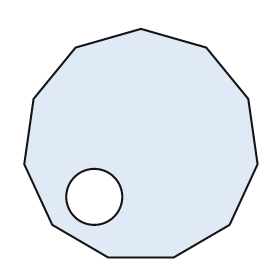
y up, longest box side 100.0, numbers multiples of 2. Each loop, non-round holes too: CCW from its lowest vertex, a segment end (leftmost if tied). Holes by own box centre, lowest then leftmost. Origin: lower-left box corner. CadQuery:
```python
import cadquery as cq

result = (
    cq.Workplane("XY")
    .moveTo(36.0, 0.0)
    .lineTo(64.0, 0.0)
    .lineTo(88.0, 14.0)
    .lineTo(100.0, 40.0)
    .lineTo(96.0, 68.0)
    .lineTo(78.0, 90.0)
    .lineTo(50.0, 98.0)
    .lineTo(22.0, 90.0)
    .lineTo(4.0, 68.0)
    .lineTo(0.0, 40.0)
    .lineTo(12.0, 14.0)
    .close()
    .moveTo(30.0, 26.0)
    .circle(12.0)
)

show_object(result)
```